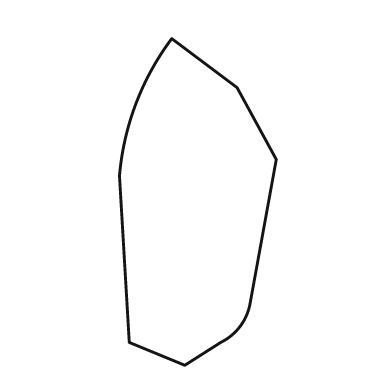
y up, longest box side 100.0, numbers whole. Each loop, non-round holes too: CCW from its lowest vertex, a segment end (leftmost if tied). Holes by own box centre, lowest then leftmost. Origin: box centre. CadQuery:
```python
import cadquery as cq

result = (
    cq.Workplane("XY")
    .moveTo(-4.0, -50.0)
    .lineTo(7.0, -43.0)
    .threePointArc((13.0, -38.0), (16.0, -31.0))
    .lineTo(24.0, 13.0)
    .lineTo(12.0, 35.0)
    .lineTo(-8.0, 50.0)
    .threePointArc((-19.0, 30.0), (-24.0, 8.0))
    .lineTo(-21.0, -43.0)
    .close()
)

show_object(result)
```